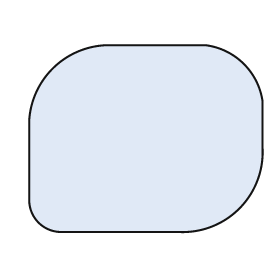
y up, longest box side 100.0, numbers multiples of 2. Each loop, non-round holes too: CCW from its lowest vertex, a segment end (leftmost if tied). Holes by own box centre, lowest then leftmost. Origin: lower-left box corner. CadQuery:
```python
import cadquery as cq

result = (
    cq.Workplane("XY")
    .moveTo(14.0, 0.0)
    .lineTo(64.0, 0.0)
    .threePointArc((90.0, 10.0), (100.0, 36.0))
    .lineTo(100.0, 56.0)
    .threePointArc((92.0, 72.0), (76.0, 80.0))
    .lineTo(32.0, 80.0)
    .threePointArc((10.0, 70.0), (0.0, 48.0))
    .lineTo(0.0, 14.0)
    .threePointArc((4.0, 4.0), (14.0, 0.0))
    .close()
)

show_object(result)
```